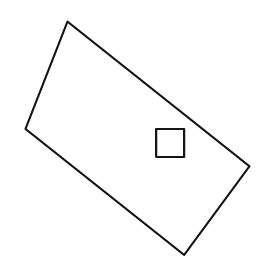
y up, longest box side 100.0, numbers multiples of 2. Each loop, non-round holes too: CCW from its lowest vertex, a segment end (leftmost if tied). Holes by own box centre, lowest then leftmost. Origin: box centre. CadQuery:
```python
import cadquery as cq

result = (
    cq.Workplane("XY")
    .moveTo(20.0, -50.0)
    .lineTo(48.0, -12.0)
    .lineTo(-30.0, 50.0)
    .lineTo(-48.0, 4.0)
    .close()
    .moveTo(8.0, -8.0)
    .lineTo(20.0, -8.0)
    .lineTo(20.0, 4.0)
    .lineTo(8.0, 4.0)
    .close()
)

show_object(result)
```